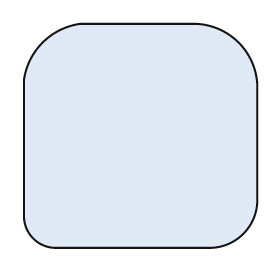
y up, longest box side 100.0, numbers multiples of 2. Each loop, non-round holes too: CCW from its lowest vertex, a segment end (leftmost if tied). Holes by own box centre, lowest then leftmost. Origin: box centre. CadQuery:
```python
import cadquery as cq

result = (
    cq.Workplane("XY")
    .moveTo(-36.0, -48.0)
    .lineTo(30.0, -48.0)
    .threePointArc((44.0, -42.0), (50.0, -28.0))
    .lineTo(50.0, 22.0)
    .threePointArc((42.0, 40.0), (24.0, 48.0))
    .lineTo(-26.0, 48.0)
    .threePointArc((-42.0, 40.0), (-50.0, 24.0))
    .lineTo(-50.0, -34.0)
    .threePointArc((-46.0, -44.0), (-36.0, -48.0))
    .close()
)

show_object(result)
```